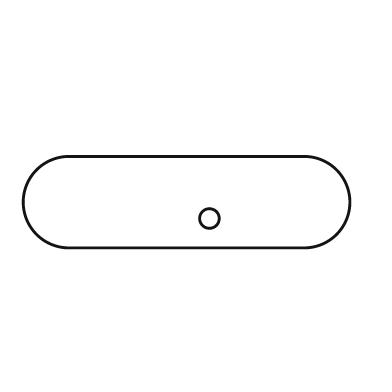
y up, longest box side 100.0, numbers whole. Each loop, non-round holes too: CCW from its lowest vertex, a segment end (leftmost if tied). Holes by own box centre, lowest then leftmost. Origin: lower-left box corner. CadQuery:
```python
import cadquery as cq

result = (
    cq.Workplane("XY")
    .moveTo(14.0, 0.0)
    .lineTo(86.0, 0.0)
    .threePointArc((100.0, 14.0), (86.0, 28.0))
    .lineTo(14.0, 28.0)
    .threePointArc((0.0, 14.0), (14.0, 0.0))
    .close()
    .moveTo(57.0, 9.0)
    .circle(3.0)
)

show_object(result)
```